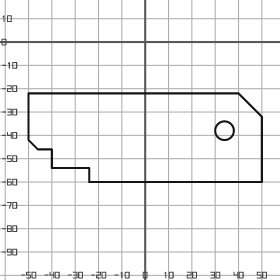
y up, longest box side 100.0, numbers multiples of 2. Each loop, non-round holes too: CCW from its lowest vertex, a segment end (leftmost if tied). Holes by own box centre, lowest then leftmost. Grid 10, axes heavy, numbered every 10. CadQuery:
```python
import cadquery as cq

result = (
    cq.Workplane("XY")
    .moveTo(-24.0, -60.0)
    .lineTo(50.0, -60.0)
    .lineTo(50.0, -32.0)
    .lineTo(40.0, -22.0)
    .lineTo(-50.0, -22.0)
    .lineTo(-50.0, -42.0)
    .lineTo(-46.0, -46.0)
    .lineTo(-40.0, -46.0)
    .lineTo(-40.0, -54.0)
    .lineTo(-24.0, -54.0)
    .close()
    .moveTo(34.0, -38.0)
    .circle(4.0)
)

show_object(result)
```